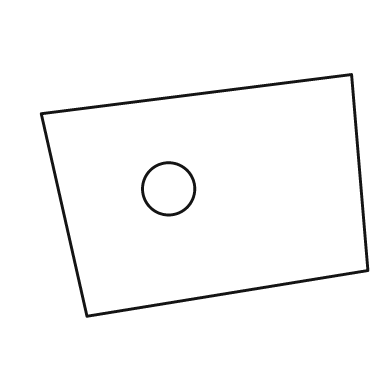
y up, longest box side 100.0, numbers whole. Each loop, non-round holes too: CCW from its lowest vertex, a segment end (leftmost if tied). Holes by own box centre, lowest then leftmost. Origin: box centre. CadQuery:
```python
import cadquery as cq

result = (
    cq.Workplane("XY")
    .moveTo(-36.0, -37.0)
    .lineTo(50.0, -23.0)
    .lineTo(45.0, 37.0)
    .lineTo(-50.0, 25.0)
    .close()
    .moveTo(-11.0, 2.0)
    .circle(8.0)
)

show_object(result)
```